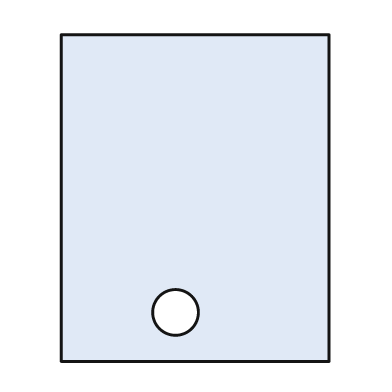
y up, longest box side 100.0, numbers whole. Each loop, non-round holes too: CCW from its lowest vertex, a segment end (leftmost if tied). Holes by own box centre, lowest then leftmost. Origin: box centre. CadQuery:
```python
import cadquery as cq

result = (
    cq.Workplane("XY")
    .moveTo(-41.0, -50.0)
    .lineTo(41.0, -50.0)
    .lineTo(41.0, 50.0)
    .lineTo(-41.0, 50.0)
    .close()
    .moveTo(-6.0, -35.0)
    .circle(7.0)
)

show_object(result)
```